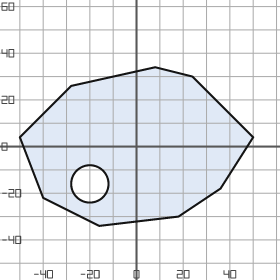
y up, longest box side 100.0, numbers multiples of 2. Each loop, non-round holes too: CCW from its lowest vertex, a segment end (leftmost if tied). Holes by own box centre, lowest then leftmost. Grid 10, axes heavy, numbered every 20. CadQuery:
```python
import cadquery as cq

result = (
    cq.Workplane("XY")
    .moveTo(-16.0, -34.0)
    .lineTo(18.0, -30.0)
    .lineTo(36.0, -18.0)
    .lineTo(50.0, 4.0)
    .lineTo(24.0, 30.0)
    .lineTo(8.0, 34.0)
    .lineTo(-28.0, 26.0)
    .lineTo(-50.0, 4.0)
    .lineTo(-40.0, -22.0)
    .close()
    .moveTo(-20.0, -16.0)
    .circle(8.0)
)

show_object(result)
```